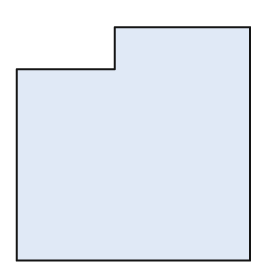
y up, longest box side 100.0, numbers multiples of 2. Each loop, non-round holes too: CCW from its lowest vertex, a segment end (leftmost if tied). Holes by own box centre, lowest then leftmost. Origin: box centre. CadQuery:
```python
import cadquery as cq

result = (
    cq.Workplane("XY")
    .moveTo(-50.0, -50.0)
    .lineTo(50.0, -50.0)
    .lineTo(50.0, 50.0)
    .lineTo(-8.0, 50.0)
    .lineTo(-8.0, 32.0)
    .lineTo(-50.0, 32.0)
    .close()
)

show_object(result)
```